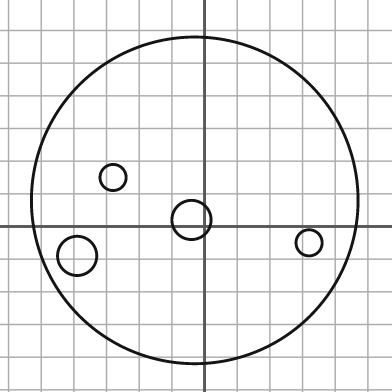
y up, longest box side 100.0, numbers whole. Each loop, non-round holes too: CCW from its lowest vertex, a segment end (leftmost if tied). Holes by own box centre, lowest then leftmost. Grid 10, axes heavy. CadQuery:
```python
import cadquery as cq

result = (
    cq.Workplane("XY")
    .moveTo(-3.0, 8.0)
    .circle(50.0)
    .moveTo(-39.0, -9.0)
    .circle(6.0)
    .moveTo(32.0, -5.0)
    .circle(4.0)
    .moveTo(-4.0, 2.0)
    .circle(6.0)
    .moveTo(-28.0, 15.0)
    .circle(4.0)
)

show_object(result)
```